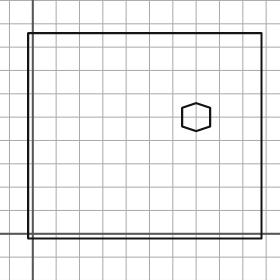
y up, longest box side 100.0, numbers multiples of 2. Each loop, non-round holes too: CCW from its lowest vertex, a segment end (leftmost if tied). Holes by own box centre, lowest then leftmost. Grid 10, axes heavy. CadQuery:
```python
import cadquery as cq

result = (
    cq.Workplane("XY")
    .moveTo(-2.0, -2.0)
    .lineTo(98.0, -2.0)
    .lineTo(98.0, 86.0)
    .lineTo(-2.0, 86.0)
    .close()
    .moveTo(70.0, 44.0)
    .lineTo(76.0, 46.0)
    .lineTo(76.0, 54.0)
    .lineTo(70.0, 56.0)
    .lineTo(64.0, 54.0)
    .lineTo(64.0, 46.0)
    .close()
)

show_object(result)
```